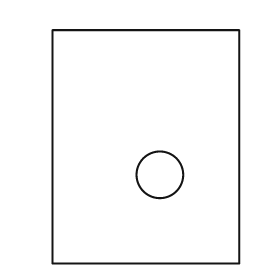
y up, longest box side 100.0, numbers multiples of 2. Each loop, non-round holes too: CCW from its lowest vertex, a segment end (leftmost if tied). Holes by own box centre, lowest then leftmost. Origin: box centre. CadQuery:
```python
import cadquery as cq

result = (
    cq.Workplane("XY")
    .moveTo(-40.0, -50.0)
    .lineTo(40.0, -50.0)
    .lineTo(40.0, 50.0)
    .lineTo(-40.0, 50.0)
    .close()
    .moveTo(6.0, -12.0)
    .circle(10.0)
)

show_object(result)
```